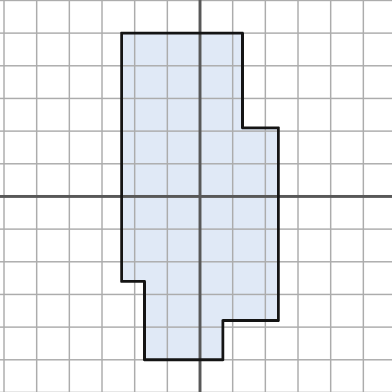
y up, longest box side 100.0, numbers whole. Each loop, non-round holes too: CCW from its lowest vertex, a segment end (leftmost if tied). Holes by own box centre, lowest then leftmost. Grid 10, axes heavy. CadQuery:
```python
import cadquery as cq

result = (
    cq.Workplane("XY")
    .moveTo(-17.0, -50.0)
    .lineTo(7.0, -50.0)
    .lineTo(7.0, -38.0)
    .lineTo(24.0, -38.0)
    .lineTo(24.0, 21.0)
    .lineTo(13.0, 21.0)
    .lineTo(13.0, 50.0)
    .lineTo(-24.0, 50.0)
    .lineTo(-24.0, -26.0)
    .lineTo(-17.0, -26.0)
    .close()
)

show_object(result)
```